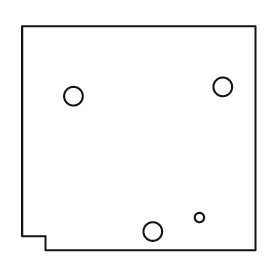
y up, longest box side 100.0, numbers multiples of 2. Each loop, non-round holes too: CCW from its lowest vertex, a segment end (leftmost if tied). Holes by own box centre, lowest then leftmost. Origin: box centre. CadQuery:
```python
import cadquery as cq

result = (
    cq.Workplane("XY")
    .moveTo(-40.0, -48.0)
    .lineTo(50.0, -48.0)
    .lineTo(50.0, 48.0)
    .lineTo(-50.0, 48.0)
    .lineTo(-50.0, -42.0)
    .lineTo(-40.0, -42.0)
    .close()
    .moveTo(6.0, -40.0)
    .circle(4.0)
    .moveTo(26.0, -34.0)
    .circle(2.0)
    .moveTo(-28.0, 18.0)
    .circle(4.0)
    .moveTo(36.0, 22.0)
    .circle(4.0)
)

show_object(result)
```